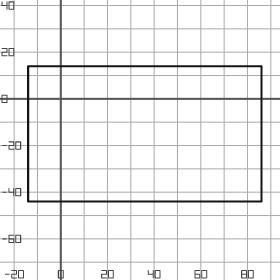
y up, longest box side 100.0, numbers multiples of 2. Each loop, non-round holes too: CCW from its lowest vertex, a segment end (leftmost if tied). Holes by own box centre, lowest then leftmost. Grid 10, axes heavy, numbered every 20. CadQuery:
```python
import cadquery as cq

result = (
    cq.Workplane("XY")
    .moveTo(-14.0, -44.0)
    .lineTo(86.0, -44.0)
    .lineTo(86.0, 14.0)
    .lineTo(-14.0, 14.0)
    .close()
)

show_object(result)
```